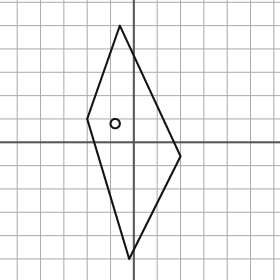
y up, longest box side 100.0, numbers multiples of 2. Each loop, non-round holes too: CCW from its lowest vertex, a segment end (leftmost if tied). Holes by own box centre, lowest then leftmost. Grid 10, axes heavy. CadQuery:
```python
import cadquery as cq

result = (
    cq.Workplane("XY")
    .moveTo(-2.0, -50.0)
    .lineTo(20.0, -6.0)
    .lineTo(-6.0, 50.0)
    .lineTo(-20.0, 10.0)
    .close()
    .moveTo(-8.0, 8.0)
    .circle(2.0)
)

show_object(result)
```